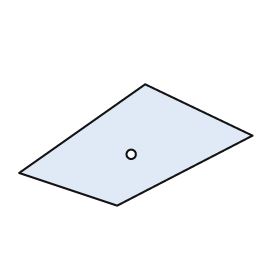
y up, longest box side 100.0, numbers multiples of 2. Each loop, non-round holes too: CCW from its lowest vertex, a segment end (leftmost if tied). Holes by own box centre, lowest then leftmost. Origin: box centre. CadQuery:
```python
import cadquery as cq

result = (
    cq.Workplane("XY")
    .moveTo(-8.0, -26.0)
    .lineTo(50.0, 4.0)
    .lineTo(4.0, 26.0)
    .lineTo(-50.0, -12.0)
    .close()
    .moveTo(-2.0, -4.0)
    .circle(2.0)
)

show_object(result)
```